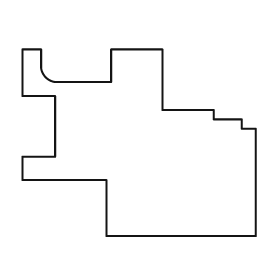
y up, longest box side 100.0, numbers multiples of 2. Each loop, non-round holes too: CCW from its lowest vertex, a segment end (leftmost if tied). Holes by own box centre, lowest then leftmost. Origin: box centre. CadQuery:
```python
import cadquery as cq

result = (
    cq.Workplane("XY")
    .moveTo(-14.0, -40.0)
    .lineTo(50.0, -40.0)
    .lineTo(50.0, 6.0)
    .lineTo(44.0, 6.0)
    .lineTo(44.0, 10.0)
    .lineTo(32.0, 10.0)
    .lineTo(32.0, 14.0)
    .lineTo(10.0, 14.0)
    .lineTo(10.0, 40.0)
    .lineTo(-12.0, 40.0)
    .lineTo(-12.0, 26.0)
    .lineTo(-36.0, 26.0)
    .threePointArc((-40.0, 28.0), (-42.0, 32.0))
    .lineTo(-42.0, 40.0)
    .lineTo(-50.0, 40.0)
    .lineTo(-50.0, 20.0)
    .lineTo(-36.0, 20.0)
    .lineTo(-36.0, -6.0)
    .lineTo(-50.0, -6.0)
    .lineTo(-50.0, -16.0)
    .lineTo(-14.0, -16.0)
    .close()
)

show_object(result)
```